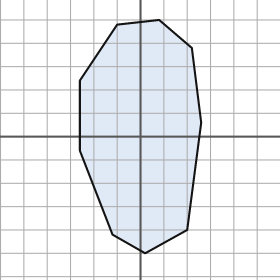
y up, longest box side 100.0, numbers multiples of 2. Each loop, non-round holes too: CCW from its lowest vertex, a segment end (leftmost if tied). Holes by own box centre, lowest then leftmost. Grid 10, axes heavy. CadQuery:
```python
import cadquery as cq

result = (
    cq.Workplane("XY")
    .moveTo(2.0, -50.0)
    .lineTo(20.0, -40.0)
    .lineTo(26.0, 6.0)
    .lineTo(22.0, 38.0)
    .lineTo(8.0, 50.0)
    .lineTo(-10.0, 48.0)
    .lineTo(-26.0, 24.0)
    .lineTo(-26.0, -6.0)
    .lineTo(-12.0, -42.0)
    .close()
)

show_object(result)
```